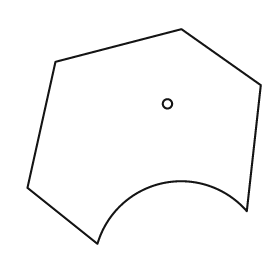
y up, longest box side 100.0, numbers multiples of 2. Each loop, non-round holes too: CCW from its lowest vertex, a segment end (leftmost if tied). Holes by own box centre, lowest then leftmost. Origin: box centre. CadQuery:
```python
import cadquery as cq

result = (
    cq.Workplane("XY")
    .moveTo(-20.0, -46.0)
    .threePointArc((8.0, -20.0), (44.0, -32.0))
    .lineTo(50.0, 22.0)
    .lineTo(16.0, 46.0)
    .lineTo(-38.0, 32.0)
    .lineTo(-50.0, -22.0)
    .close()
    .moveTo(10.0, 14.0)
    .circle(2.0)
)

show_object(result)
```